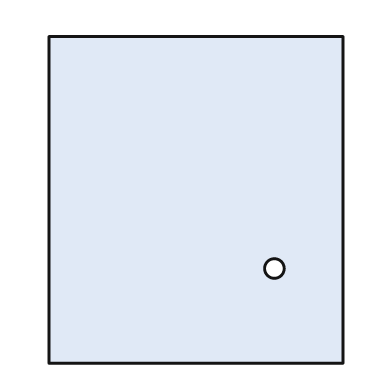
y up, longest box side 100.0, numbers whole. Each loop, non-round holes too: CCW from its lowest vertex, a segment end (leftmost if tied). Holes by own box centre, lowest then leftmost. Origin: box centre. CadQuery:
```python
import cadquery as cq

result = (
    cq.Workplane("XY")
    .moveTo(-45.0, -50.0)
    .lineTo(45.0, -50.0)
    .lineTo(45.0, 50.0)
    .lineTo(-45.0, 50.0)
    .close()
    .moveTo(24.0, -21.0)
    .circle(3.0)
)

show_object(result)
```